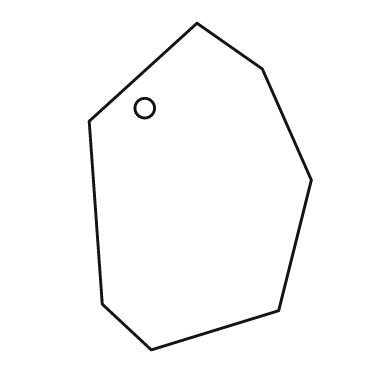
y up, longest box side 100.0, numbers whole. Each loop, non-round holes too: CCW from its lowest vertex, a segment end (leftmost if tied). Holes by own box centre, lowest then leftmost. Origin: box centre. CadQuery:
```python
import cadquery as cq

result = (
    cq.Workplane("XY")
    .moveTo(-15.0, -50.0)
    .lineTo(24.0, -38.0)
    .lineTo(34.0, 2.0)
    .lineTo(19.0, 36.0)
    .lineTo(-1.0, 50.0)
    .lineTo(-34.0, 20.0)
    .lineTo(-30.0, -36.0)
    .close()
    .moveTo(-17.0, 24.0)
    .circle(3.0)
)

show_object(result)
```